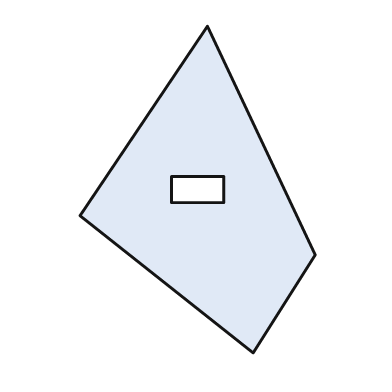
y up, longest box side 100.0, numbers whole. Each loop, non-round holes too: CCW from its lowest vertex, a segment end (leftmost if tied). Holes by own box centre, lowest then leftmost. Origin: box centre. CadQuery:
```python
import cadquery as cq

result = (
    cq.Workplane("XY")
    .moveTo(17.0, -50.0)
    .lineTo(36.0, -20.0)
    .lineTo(3.0, 50.0)
    .lineTo(-36.0, -8.0)
    .close()
    .moveTo(-8.0, -4.0)
    .lineTo(8.0, -4.0)
    .lineTo(8.0, 4.0)
    .lineTo(-8.0, 4.0)
    .close()
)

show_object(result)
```